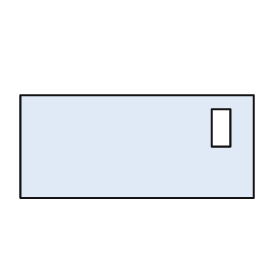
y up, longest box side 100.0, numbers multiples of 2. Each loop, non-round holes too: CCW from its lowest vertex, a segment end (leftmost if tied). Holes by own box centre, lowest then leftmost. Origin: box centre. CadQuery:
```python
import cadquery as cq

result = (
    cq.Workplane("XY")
    .moveTo(-50.0, -22.0)
    .lineTo(50.0, -22.0)
    .lineTo(50.0, 22.0)
    .lineTo(-50.0, 22.0)
    .close()
    .moveTo(32.0, 0.0)
    .lineTo(40.0, 0.0)
    .lineTo(40.0, 16.0)
    .lineTo(32.0, 16.0)
    .close()
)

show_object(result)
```